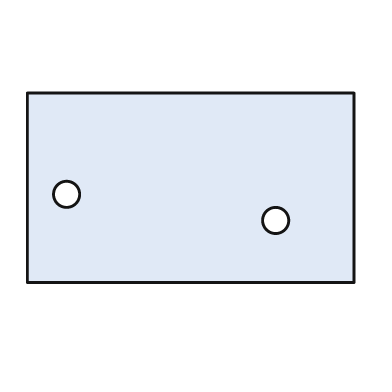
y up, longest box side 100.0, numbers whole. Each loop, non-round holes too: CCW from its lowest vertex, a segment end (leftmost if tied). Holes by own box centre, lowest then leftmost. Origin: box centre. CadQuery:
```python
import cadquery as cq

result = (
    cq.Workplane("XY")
    .moveTo(-50.0, -29.0)
    .lineTo(50.0, -29.0)
    .lineTo(50.0, 29.0)
    .lineTo(-50.0, 29.0)
    .close()
    .moveTo(26.0, -10.0)
    .circle(4.0)
    .moveTo(-38.0, -2.0)
    .circle(4.0)
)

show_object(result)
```